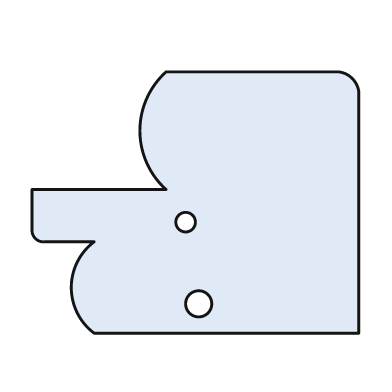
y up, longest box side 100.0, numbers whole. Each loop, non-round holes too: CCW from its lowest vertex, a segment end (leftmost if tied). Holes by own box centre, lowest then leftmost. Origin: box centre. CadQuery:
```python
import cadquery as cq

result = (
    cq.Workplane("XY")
    .moveTo(-31.0, -40.0)
    .lineTo(50.0, -40.0)
    .lineTo(50.0, 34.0)
    .threePointArc((48.0, 38.0), (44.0, 40.0))
    .lineTo(-9.0, 40.0)
    .threePointArc((-17.0, 22.0), (-9.0, 4.0))
    .lineTo(-50.0, 4.0)
    .lineTo(-50.0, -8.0)
    .threePointArc((-49.0, -11.0), (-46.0, -12.0))
    .lineTo(-31.0, -12.0)
    .threePointArc((-38.0, -26.0), (-31.0, -40.0))
    .close()
    .moveTo(1.0, -31.0)
    .circle(4.0)
    .moveTo(-3.0, -6.0)
    .circle(3.0)
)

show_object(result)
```